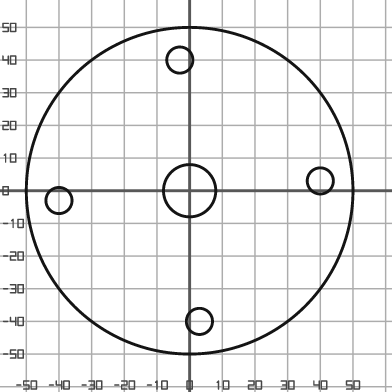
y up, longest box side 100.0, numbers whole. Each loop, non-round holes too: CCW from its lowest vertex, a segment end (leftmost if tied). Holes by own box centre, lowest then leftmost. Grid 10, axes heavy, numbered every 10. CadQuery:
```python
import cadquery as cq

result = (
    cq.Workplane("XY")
    .moveTo(0.0, 0.0)
    .circle(50.0)
    .moveTo(3.0, -40.0)
    .circle(4.0)
    .moveTo(-40.0, -3.0)
    .circle(4.0)
    .moveTo(0.0, 0.0)
    .circle(8.0)
    .moveTo(40.0, 3.0)
    .circle(4.0)
    .moveTo(-3.0, 40.0)
    .circle(4.0)
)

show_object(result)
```